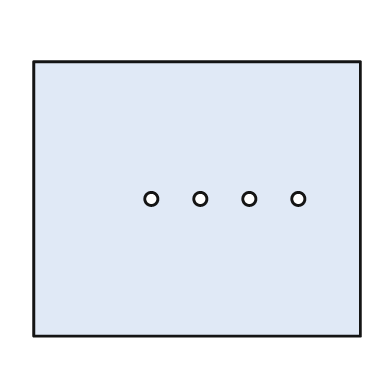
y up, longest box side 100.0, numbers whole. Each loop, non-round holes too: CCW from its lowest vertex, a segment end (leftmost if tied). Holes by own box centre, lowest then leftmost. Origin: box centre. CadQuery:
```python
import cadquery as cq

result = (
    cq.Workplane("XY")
    .moveTo(-50.0, -42.0)
    .lineTo(50.0, -42.0)
    .lineTo(50.0, 42.0)
    .lineTo(-50.0, 42.0)
    .close()
    .moveTo(-14.0, 0.0)
    .circle(2.0)
    .moveTo(1.0, 0.0)
    .circle(2.0)
    .moveTo(16.0, 0.0)
    .circle(2.0)
    .moveTo(31.0, 0.0)
    .circle(2.0)
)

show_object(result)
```